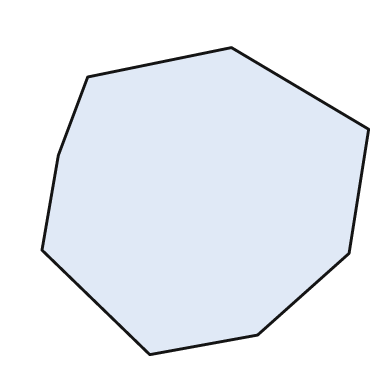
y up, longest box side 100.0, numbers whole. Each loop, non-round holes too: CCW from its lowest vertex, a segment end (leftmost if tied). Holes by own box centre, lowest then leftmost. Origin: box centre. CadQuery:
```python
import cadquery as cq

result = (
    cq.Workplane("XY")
    .moveTo(-17.0, -47.0)
    .lineTo(16.0, -41.0)
    .lineTo(44.0, -16.0)
    .lineTo(50.0, 22.0)
    .lineTo(8.0, 47.0)
    .lineTo(-36.0, 38.0)
    .lineTo(-45.0, 14.0)
    .lineTo(-50.0, -15.0)
    .close()
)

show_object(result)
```